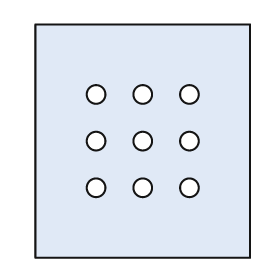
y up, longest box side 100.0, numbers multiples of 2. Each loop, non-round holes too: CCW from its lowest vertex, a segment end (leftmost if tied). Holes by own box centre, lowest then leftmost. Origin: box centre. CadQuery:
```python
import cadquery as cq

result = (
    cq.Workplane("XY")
    .moveTo(-46.0, -50.0)
    .lineTo(46.0, -50.0)
    .lineTo(46.0, 50.0)
    .lineTo(-46.0, 50.0)
    .close()
    .moveTo(-20.0, -20.0)
    .circle(4.0)
    .moveTo(0.0, -20.0)
    .circle(4.0)
    .moveTo(20.0, -20.0)
    .circle(4.0)
    .moveTo(-20.0, 0.0)
    .circle(4.0)
    .moveTo(0.0, 0.0)
    .circle(4.0)
    .moveTo(20.0, 0.0)
    .circle(4.0)
    .moveTo(-20.0, 20.0)
    .circle(4.0)
    .moveTo(0.0, 20.0)
    .circle(4.0)
    .moveTo(20.0, 20.0)
    .circle(4.0)
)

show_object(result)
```